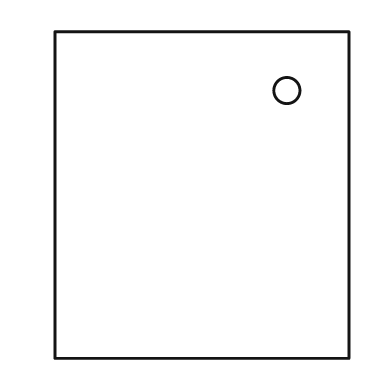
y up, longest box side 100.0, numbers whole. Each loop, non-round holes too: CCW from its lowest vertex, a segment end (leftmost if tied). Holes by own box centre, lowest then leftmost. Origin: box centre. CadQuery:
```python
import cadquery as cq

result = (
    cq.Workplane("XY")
    .moveTo(-45.0, -50.0)
    .lineTo(45.0, -50.0)
    .lineTo(45.0, 50.0)
    .lineTo(-45.0, 50.0)
    .close()
    .moveTo(26.0, 32.0)
    .circle(4.0)
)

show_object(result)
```